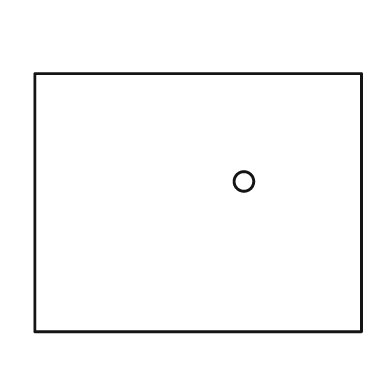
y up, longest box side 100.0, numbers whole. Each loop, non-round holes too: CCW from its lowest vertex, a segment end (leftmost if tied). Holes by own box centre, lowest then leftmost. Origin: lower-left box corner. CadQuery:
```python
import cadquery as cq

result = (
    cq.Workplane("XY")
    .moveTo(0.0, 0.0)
    .lineTo(100.0, 0.0)
    .lineTo(100.0, 79.0)
    .lineTo(0.0, 79.0)
    .close()
    .moveTo(64.0, 46.0)
    .circle(3.0)
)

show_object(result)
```